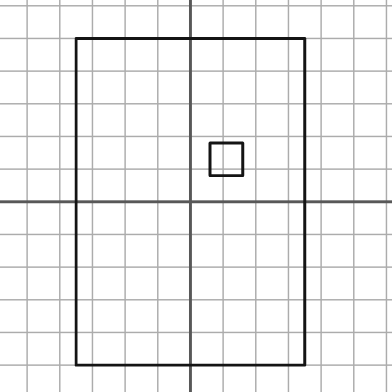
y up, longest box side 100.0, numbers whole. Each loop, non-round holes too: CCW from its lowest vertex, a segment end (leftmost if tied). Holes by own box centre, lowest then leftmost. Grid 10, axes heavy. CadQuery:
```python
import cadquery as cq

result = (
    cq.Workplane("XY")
    .moveTo(-35.0, -50.0)
    .lineTo(35.0, -50.0)
    .lineTo(35.0, 50.0)
    .lineTo(-35.0, 50.0)
    .close()
    .moveTo(6.0, 8.0)
    .lineTo(16.0, 8.0)
    .lineTo(16.0, 18.0)
    .lineTo(6.0, 18.0)
    .close()
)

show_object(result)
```